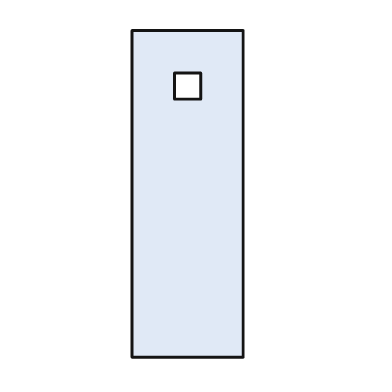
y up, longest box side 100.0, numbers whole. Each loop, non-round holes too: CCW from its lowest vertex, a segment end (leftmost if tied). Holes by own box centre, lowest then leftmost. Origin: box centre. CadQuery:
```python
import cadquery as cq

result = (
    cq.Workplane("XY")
    .moveTo(-17.0, -50.0)
    .lineTo(17.0, -50.0)
    .lineTo(17.0, 50.0)
    .lineTo(-17.0, 50.0)
    .close()
    .moveTo(-4.0, 29.0)
    .lineTo(4.0, 29.0)
    .lineTo(4.0, 37.0)
    .lineTo(-4.0, 37.0)
    .close()
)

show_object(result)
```